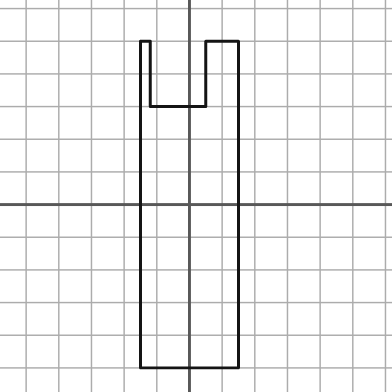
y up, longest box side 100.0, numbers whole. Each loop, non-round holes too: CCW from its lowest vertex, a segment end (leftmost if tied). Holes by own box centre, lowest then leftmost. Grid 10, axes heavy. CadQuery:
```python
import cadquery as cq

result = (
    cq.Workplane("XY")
    .moveTo(-15.0, -50.0)
    .lineTo(15.0, -50.0)
    .lineTo(15.0, 50.0)
    .lineTo(5.0, 50.0)
    .lineTo(5.0, 30.0)
    .lineTo(-12.0, 30.0)
    .lineTo(-12.0, 50.0)
    .lineTo(-15.0, 50.0)
    .close()
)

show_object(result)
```